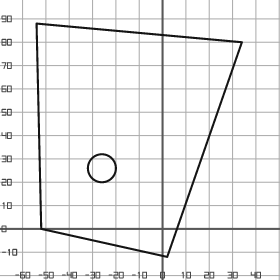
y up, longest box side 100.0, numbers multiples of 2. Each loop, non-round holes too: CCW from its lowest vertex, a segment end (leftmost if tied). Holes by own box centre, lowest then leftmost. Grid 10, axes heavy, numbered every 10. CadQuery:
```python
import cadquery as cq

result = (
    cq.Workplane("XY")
    .moveTo(2.0, -12.0)
    .lineTo(34.0, 80.0)
    .lineTo(-54.0, 88.0)
    .lineTo(-52.0, 0.0)
    .close()
    .moveTo(-26.0, 26.0)
    .circle(6.0)
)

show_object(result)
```